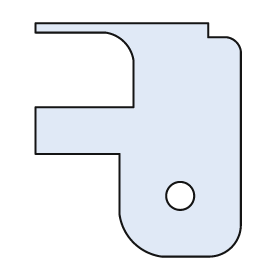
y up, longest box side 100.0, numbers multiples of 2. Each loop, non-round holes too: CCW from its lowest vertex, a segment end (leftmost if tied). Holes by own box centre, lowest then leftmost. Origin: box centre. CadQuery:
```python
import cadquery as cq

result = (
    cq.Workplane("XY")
    .moveTo(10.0, -50.0)
    .lineTo(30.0, -50.0)
    .threePointArc((40.0, -46.0), (44.0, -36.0))
    .lineTo(44.0, 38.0)
    .threePointArc((42.0, 42.0), (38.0, 44.0))
    .lineTo(30.0, 44.0)
    .lineTo(30.0, 50.0)
    .lineTo(-44.0, 50.0)
    .lineTo(-44.0, 46.0)
    .lineTo(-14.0, 46.0)
    .threePointArc((-6.0, 42.0), (-2.0, 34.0))
    .lineTo(-2.0, 14.0)
    .lineTo(-44.0, 14.0)
    .lineTo(-44.0, -6.0)
    .lineTo(-8.0, -6.0)
    .lineTo(-8.0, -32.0)
    .threePointArc((-2.0, -44.0), (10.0, -50.0))
    .close()
    .moveTo(18.0, -24.0)
    .circle(6.0)
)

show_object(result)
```